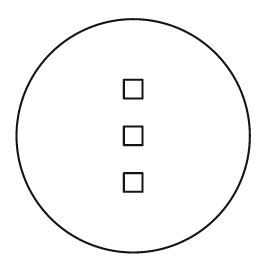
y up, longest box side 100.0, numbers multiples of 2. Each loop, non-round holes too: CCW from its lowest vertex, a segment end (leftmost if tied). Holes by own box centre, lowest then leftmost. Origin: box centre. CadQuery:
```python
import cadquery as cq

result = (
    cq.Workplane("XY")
    .moveTo(0.0, 0.0)
    .circle(50.0)
    .moveTo(-4.0, -24.0)
    .lineTo(4.0, -24.0)
    .lineTo(4.0, -16.0)
    .lineTo(-4.0, -16.0)
    .close()
    .moveTo(-4.0, -4.0)
    .lineTo(4.0, -4.0)
    .lineTo(4.0, 4.0)
    .lineTo(-4.0, 4.0)
    .close()
    .moveTo(-4.0, 16.0)
    .lineTo(4.0, 16.0)
    .lineTo(4.0, 24.0)
    .lineTo(-4.0, 24.0)
    .close()
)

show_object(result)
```